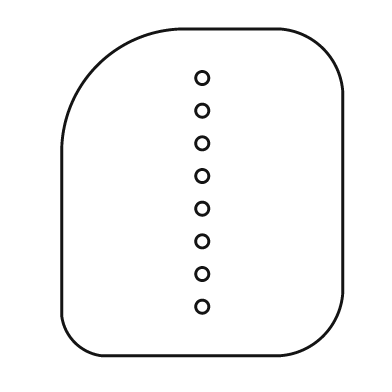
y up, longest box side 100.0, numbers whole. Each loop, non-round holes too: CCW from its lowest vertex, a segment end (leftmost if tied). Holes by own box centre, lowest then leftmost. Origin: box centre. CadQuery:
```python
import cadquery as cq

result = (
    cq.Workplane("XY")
    .moveTo(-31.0, -50.0)
    .lineTo(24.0, -50.0)
    .threePointArc((37.0, -44.0), (43.0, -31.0))
    .lineTo(43.0, 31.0)
    .threePointArc((37.0, 44.0), (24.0, 50.0))
    .lineTo(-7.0, 50.0)
    .threePointArc((-32.0, 39.0), (-43.0, 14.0))
    .lineTo(-43.0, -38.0)
    .threePointArc((-39.0, -46.0), (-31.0, -50.0))
    .close()
    .moveTo(0.0, -35.0)
    .circle(2.0)
    .moveTo(0.0, -25.0)
    .circle(2.0)
    .moveTo(0.0, -15.0)
    .circle(2.0)
    .moveTo(0.0, -5.0)
    .circle(2.0)
    .moveTo(0.0, 5.0)
    .circle(2.0)
    .moveTo(0.0, 15.0)
    .circle(2.0)
    .moveTo(0.0, 25.0)
    .circle(2.0)
    .moveTo(0.0, 35.0)
    .circle(2.0)
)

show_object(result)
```